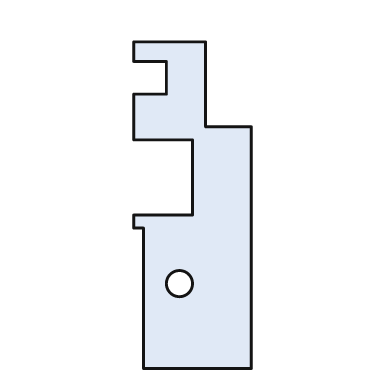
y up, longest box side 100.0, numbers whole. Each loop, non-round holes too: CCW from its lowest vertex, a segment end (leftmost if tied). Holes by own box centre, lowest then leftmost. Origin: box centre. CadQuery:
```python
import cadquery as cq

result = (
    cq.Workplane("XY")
    .moveTo(-15.0, -50.0)
    .lineTo(18.0, -50.0)
    .lineTo(18.0, 24.0)
    .lineTo(4.0, 24.0)
    .lineTo(4.0, 50.0)
    .lineTo(-18.0, 50.0)
    .lineTo(-18.0, 44.0)
    .lineTo(-8.0, 44.0)
    .lineTo(-8.0, 34.0)
    .lineTo(-18.0, 34.0)
    .lineTo(-18.0, 20.0)
    .lineTo(0.0, 20.0)
    .lineTo(0.0, -3.0)
    .lineTo(-18.0, -3.0)
    .lineTo(-18.0, -7.0)
    .lineTo(-15.0, -7.0)
    .close()
    .moveTo(-4.0, -24.0)
    .circle(4.0)
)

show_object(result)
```